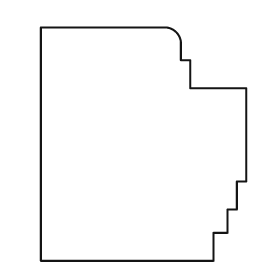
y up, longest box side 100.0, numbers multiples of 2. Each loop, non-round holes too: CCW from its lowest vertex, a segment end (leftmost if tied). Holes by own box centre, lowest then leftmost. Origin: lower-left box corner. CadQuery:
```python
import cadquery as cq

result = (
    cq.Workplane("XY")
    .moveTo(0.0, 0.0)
    .lineTo(74.0, 0.0)
    .lineTo(74.0, 12.0)
    .lineTo(80.0, 12.0)
    .lineTo(80.0, 22.0)
    .lineTo(84.0, 22.0)
    .lineTo(84.0, 34.0)
    .lineTo(88.0, 34.0)
    .lineTo(88.0, 74.0)
    .lineTo(64.0, 74.0)
    .lineTo(64.0, 86.0)
    .lineTo(60.0, 86.0)
    .lineTo(60.0, 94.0)
    .threePointArc((58.0, 98.0), (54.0, 100.0))
    .lineTo(0.0, 100.0)
    .close()
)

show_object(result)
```